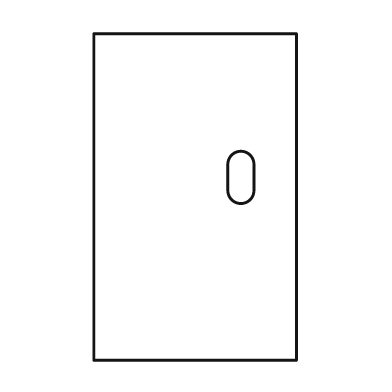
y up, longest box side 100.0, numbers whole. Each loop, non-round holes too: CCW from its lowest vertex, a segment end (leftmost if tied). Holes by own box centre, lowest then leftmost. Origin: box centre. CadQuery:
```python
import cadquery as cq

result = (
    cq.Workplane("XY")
    .moveTo(-31.0, -50.0)
    .lineTo(31.0, -50.0)
    .lineTo(31.0, 50.0)
    .lineTo(-31.0, 50.0)
    .close()
    .moveTo(10.0, 2.0)
    .threePointArc((14.0, -2.0), (18.0, 2.0))
    .lineTo(18.0, 10.0)
    .threePointArc((14.0, 14.0), (10.0, 10.0))
    .close()
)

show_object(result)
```